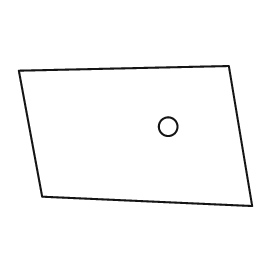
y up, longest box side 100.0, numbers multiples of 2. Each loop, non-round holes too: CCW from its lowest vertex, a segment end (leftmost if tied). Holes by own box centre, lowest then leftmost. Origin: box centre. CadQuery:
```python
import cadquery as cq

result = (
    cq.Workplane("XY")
    .moveTo(50.0, -30.0)
    .lineTo(40.0, 30.0)
    .lineTo(-50.0, 28.0)
    .lineTo(-40.0, -26.0)
    .close()
    .moveTo(14.0, 4.0)
    .circle(4.0)
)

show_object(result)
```